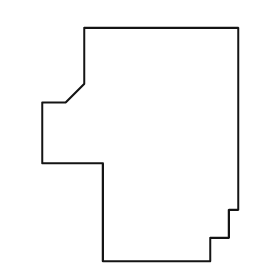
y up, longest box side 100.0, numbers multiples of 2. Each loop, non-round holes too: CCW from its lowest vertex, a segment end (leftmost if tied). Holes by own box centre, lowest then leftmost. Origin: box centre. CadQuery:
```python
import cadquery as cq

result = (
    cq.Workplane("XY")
    .moveTo(-16.0, -50.0)
    .lineTo(30.0, -50.0)
    .lineTo(30.0, -40.0)
    .lineTo(38.0, -40.0)
    .lineTo(38.0, -28.0)
    .lineTo(42.0, -28.0)
    .lineTo(42.0, 50.0)
    .lineTo(-24.0, 50.0)
    .lineTo(-24.0, 26.0)
    .lineTo(-32.0, 18.0)
    .lineTo(-42.0, 18.0)
    .lineTo(-42.0, -8.0)
    .lineTo(-16.0, -8.0)
    .close()
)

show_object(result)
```